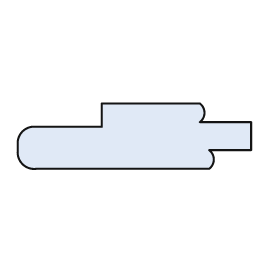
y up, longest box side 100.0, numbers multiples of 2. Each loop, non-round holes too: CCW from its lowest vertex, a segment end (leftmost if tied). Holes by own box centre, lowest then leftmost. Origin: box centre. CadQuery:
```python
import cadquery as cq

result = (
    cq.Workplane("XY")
    .moveTo(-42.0, -14.0)
    .lineTo(32.0, -14.0)
    .threePointArc((34.0, -10.0), (32.0, -6.0))
    .lineTo(50.0, -6.0)
    .lineTo(50.0, 6.0)
    .lineTo(28.0, 6.0)
    .threePointArc((30.0, 10.0), (28.0, 14.0))
    .lineTo(-14.0, 14.0)
    .lineTo(-14.0, 4.0)
    .lineTo(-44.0, 4.0)
    .threePointArc((-48.0, 2.0), (-50.0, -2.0))
    .lineTo(-50.0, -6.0)
    .threePointArc((-48.0, -12.0), (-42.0, -14.0))
    .close()
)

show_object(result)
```